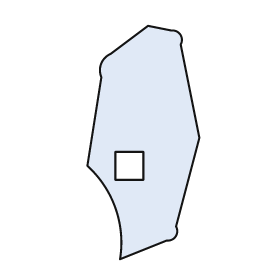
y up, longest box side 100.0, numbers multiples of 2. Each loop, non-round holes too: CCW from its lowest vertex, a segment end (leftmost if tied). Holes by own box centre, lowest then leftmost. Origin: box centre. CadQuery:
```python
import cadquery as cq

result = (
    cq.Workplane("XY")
    .moveTo(-10.0, -50.0)
    .lineTo(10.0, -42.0)
    .threePointArc((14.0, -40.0), (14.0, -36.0))
    .lineTo(24.0, 2.0)
    .lineTo(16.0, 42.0)
    .threePointArc((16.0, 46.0), (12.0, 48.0))
    .lineTo(2.0, 50.0)
    .lineTo(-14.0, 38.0)
    .threePointArc((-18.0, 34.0), (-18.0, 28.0))
    .lineTo(-24.0, -10.0)
    .threePointArc((-12.0, -28.0), (-10.0, -50.0))
    .close()
    .moveTo(-12.0, -16.0)
    .lineTo(0.0, -16.0)
    .lineTo(0.0, -4.0)
    .lineTo(-12.0, -4.0)
    .close()
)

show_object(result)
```